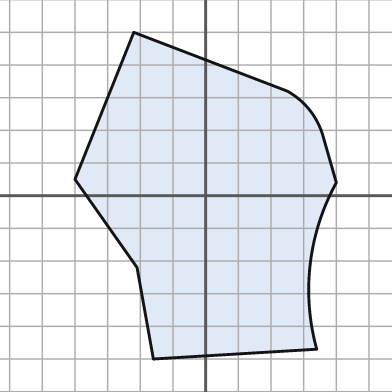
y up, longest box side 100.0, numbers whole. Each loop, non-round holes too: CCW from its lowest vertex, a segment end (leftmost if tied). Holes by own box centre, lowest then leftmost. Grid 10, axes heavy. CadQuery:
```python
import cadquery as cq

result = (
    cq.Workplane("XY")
    .moveTo(-16.0, -50.0)
    .lineTo(34.0, -47.0)
    .threePointArc((32.0, -21.0), (40.0, 4.0))
    .lineTo(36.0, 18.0)
    .threePointArc((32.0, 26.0), (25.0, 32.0))
    .lineTo(-22.0, 50.0)
    .lineTo(-40.0, 5.0)
    .lineTo(-21.0, -22.0)
    .close()
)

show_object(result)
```